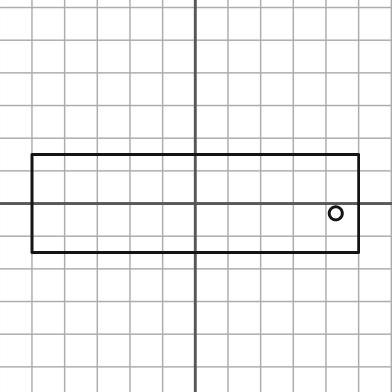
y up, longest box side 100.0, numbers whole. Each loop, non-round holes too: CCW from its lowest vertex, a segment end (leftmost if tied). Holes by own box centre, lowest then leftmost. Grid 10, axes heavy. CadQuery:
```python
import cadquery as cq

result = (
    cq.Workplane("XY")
    .moveTo(-50.0, -15.0)
    .lineTo(50.0, -15.0)
    .lineTo(50.0, 15.0)
    .lineTo(-50.0, 15.0)
    .close()
    .moveTo(43.0, -3.0)
    .circle(2.0)
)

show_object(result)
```